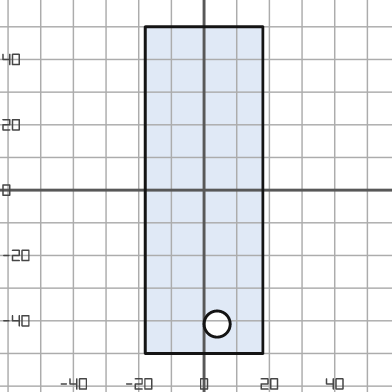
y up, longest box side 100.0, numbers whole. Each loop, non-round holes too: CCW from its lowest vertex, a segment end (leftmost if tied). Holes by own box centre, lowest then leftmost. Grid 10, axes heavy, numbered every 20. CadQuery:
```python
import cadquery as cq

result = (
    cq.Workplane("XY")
    .moveTo(-18.0, -50.0)
    .lineTo(18.0, -50.0)
    .lineTo(18.0, 50.0)
    .lineTo(-18.0, 50.0)
    .close()
    .moveTo(4.0, -41.0)
    .circle(4.0)
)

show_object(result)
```